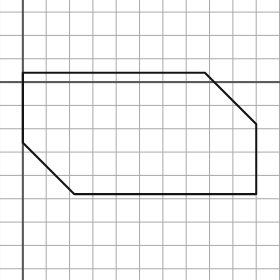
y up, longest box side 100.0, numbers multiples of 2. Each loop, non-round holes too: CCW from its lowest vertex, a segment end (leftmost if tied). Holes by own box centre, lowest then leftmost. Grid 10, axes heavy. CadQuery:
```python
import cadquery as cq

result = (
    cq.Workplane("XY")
    .moveTo(22.0, -48.0)
    .lineTo(100.0, -48.0)
    .lineTo(100.0, -18.0)
    .lineTo(78.0, 4.0)
    .lineTo(0.0, 4.0)
    .lineTo(0.0, -26.0)
    .close()
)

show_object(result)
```